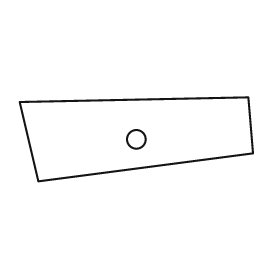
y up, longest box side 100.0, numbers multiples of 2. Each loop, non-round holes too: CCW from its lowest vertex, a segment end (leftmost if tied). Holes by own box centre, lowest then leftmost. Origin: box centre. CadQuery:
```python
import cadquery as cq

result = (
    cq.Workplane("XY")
    .moveTo(-42.0, -18.0)
    .lineTo(50.0, -6.0)
    .lineTo(48.0, 18.0)
    .lineTo(-50.0, 16.0)
    .close()
    .moveTo(0.0, 0.0)
    .circle(4.0)
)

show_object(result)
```